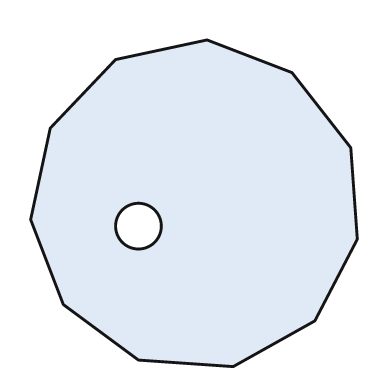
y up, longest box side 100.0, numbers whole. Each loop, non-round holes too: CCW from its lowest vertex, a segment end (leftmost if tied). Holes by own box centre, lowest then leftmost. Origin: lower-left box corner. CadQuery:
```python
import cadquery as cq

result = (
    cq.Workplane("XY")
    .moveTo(62.0, 0.0)
    .lineTo(87.0, 14.0)
    .lineTo(100.0, 39.0)
    .lineTo(98.0, 67.0)
    .lineTo(80.0, 90.0)
    .lineTo(54.0, 100.0)
    .lineTo(26.0, 94.0)
    .lineTo(6.0, 73.0)
    .lineTo(0.0, 45.0)
    .lineTo(10.0, 19.0)
    .lineTo(33.0, 2.0)
    .close()
    .moveTo(33.0, 43.0)
    .circle(7.0)
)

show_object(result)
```